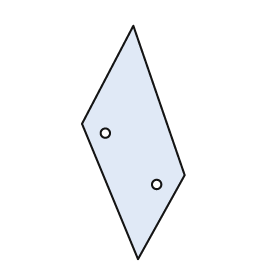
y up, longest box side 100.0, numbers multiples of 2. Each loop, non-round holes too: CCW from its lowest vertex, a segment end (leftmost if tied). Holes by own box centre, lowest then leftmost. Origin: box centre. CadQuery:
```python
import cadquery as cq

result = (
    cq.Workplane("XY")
    .moveTo(2.0, -50.0)
    .lineTo(22.0, -14.0)
    .lineTo(0.0, 50.0)
    .lineTo(-22.0, 8.0)
    .close()
    .moveTo(10.0, -18.0)
    .circle(2.0)
    .moveTo(-12.0, 4.0)
    .circle(2.0)
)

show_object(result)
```